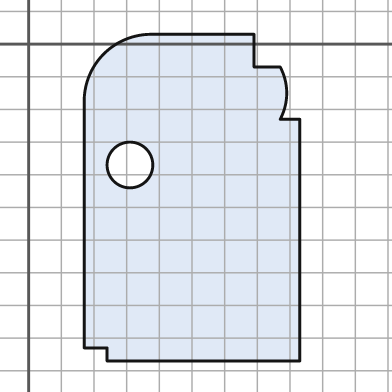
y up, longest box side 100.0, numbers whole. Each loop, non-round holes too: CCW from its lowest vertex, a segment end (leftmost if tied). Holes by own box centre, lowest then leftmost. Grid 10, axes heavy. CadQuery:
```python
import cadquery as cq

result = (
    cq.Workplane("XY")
    .moveTo(24.0, -97.0)
    .lineTo(83.0, -97.0)
    .lineTo(83.0, -23.0)
    .lineTo(77.0, -23.0)
    .threePointArc((79.0, -15.0), (77.0, -7.0))
    .lineTo(69.0, -7.0)
    .lineTo(69.0, 3.0)
    .lineTo(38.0, 3.0)
    .threePointArc((23.0, -3.0), (17.0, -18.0))
    .lineTo(17.0, -93.0)
    .lineTo(24.0, -93.0)
    .close()
    .moveTo(31.0, -37.0)
    .circle(7.0)
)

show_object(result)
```